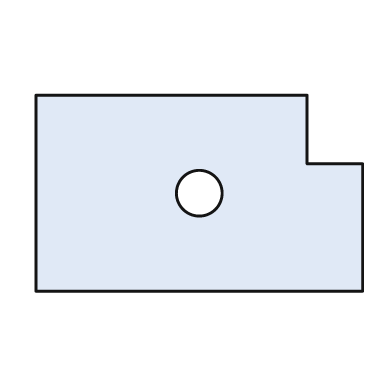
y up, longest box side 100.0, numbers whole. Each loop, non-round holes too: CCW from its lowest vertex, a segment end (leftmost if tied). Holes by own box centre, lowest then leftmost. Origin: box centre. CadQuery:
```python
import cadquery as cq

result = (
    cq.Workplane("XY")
    .moveTo(-50.0, -30.0)
    .lineTo(50.0, -30.0)
    .lineTo(50.0, 9.0)
    .lineTo(33.0, 9.0)
    .lineTo(33.0, 30.0)
    .lineTo(-50.0, 30.0)
    .close()
    .moveTo(0.0, 0.0)
    .circle(7.0)
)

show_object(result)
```